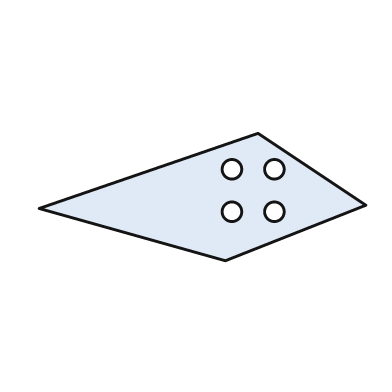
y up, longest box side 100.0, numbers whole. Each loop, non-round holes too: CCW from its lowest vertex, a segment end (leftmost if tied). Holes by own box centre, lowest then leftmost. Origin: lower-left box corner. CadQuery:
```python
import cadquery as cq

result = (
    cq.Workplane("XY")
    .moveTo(57.0, 0.0)
    .lineTo(100.0, 17.0)
    .lineTo(67.0, 39.0)
    .lineTo(0.0, 16.0)
    .close()
    .moveTo(59.0, 15.0)
    .circle(3.0)
    .moveTo(72.0, 15.0)
    .circle(3.0)
    .moveTo(59.0, 28.0)
    .circle(3.0)
    .moveTo(72.0, 28.0)
    .circle(3.0)
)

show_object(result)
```